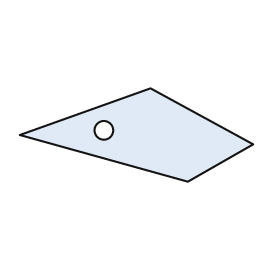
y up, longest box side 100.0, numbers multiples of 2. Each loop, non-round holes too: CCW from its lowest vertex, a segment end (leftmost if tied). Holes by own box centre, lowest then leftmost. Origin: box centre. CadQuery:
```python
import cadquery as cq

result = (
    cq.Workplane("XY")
    .moveTo(22.0, -20.0)
    .lineTo(50.0, -4.0)
    .lineTo(6.0, 20.0)
    .lineTo(-50.0, 0.0)
    .close()
    .moveTo(-14.0, 2.0)
    .circle(4.0)
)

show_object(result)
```